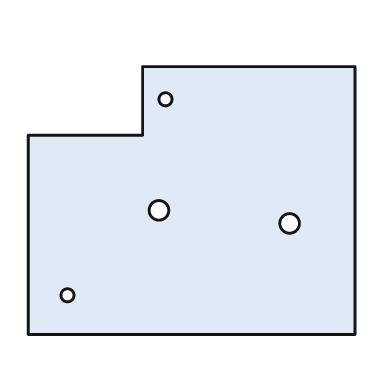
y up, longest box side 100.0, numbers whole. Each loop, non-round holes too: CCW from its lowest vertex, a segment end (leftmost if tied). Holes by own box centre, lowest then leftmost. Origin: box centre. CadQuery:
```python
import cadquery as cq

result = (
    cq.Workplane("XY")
    .moveTo(-50.0, -41.0)
    .lineTo(50.0, -41.0)
    .lineTo(50.0, 41.0)
    .lineTo(-15.0, 41.0)
    .lineTo(-15.0, 20.0)
    .lineTo(-50.0, 20.0)
    .close()
    .moveTo(-38.0, -29.0)
    .circle(2.0)
    .moveTo(30.0, -7.0)
    .circle(3.0)
    .moveTo(-10.0, -3.0)
    .circle(3.0)
    .moveTo(-8.0, 31.0)
    .circle(2.0)
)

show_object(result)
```